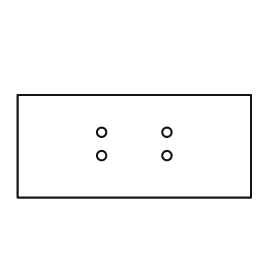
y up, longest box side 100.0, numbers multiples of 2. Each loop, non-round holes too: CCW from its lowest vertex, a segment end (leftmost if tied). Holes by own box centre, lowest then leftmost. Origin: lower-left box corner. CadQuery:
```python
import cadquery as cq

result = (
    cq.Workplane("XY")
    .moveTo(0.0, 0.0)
    .lineTo(100.0, 0.0)
    .lineTo(100.0, 44.0)
    .lineTo(0.0, 44.0)
    .close()
    .moveTo(36.0, 18.0)
    .circle(2.0)
    .moveTo(64.0, 18.0)
    .circle(2.0)
    .moveTo(36.0, 28.0)
    .circle(2.0)
    .moveTo(64.0, 28.0)
    .circle(2.0)
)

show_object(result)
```